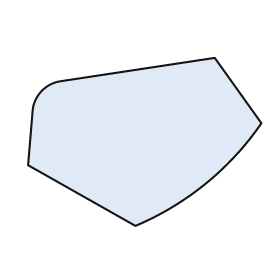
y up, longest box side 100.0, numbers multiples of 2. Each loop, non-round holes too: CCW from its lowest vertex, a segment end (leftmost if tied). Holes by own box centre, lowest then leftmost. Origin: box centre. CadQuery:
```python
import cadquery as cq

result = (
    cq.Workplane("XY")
    .moveTo(-4.0, -36.0)
    .threePointArc((26.0, -18.0), (50.0, 8.0))
    .lineTo(30.0, 36.0)
    .lineTo(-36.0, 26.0)
    .threePointArc((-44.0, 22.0), (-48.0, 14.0))
    .lineTo(-50.0, -10.0)
    .close()
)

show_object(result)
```